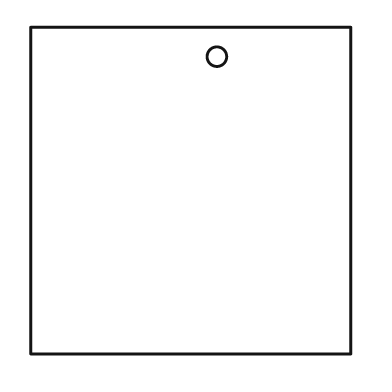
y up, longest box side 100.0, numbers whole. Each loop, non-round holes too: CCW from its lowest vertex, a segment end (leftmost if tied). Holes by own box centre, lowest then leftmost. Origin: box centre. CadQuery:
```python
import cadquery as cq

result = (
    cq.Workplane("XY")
    .moveTo(-49.0, -50.0)
    .lineTo(49.0, -50.0)
    .lineTo(49.0, 50.0)
    .lineTo(-49.0, 50.0)
    .close()
    .moveTo(8.0, 41.0)
    .circle(3.0)
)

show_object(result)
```